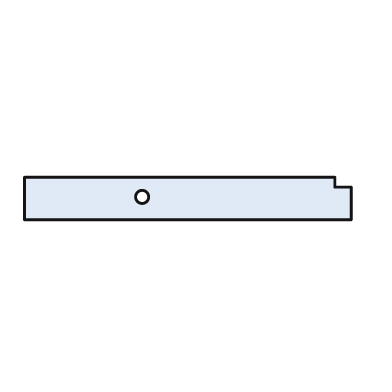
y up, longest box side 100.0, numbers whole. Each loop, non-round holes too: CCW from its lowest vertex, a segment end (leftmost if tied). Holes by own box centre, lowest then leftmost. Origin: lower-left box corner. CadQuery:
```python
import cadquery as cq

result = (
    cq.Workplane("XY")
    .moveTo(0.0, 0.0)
    .lineTo(100.0, 0.0)
    .lineTo(100.0, 10.0)
    .lineTo(95.0, 10.0)
    .lineTo(95.0, 13.0)
    .lineTo(0.0, 13.0)
    .close()
    .moveTo(36.0, 7.0)
    .circle(2.0)
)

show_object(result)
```